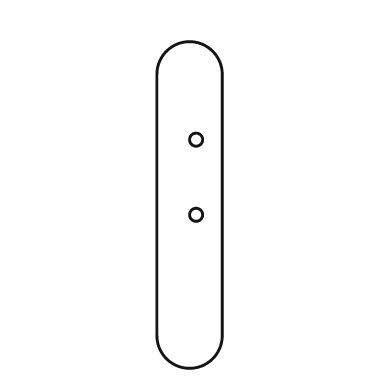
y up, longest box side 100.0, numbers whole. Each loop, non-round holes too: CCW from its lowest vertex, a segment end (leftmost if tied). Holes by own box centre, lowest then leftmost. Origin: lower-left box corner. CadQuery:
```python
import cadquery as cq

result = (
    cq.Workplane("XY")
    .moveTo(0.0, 10.0)
    .threePointArc((10.0, 0.0), (20.0, 10.0))
    .lineTo(20.0, 90.0)
    .threePointArc((10.0, 100.0), (0.0, 90.0))
    .close()
    .moveTo(12.0, 47.0)
    .circle(2.0)
    .moveTo(12.0, 70.0)
    .circle(2.0)
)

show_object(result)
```